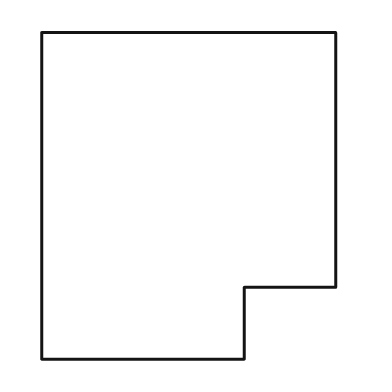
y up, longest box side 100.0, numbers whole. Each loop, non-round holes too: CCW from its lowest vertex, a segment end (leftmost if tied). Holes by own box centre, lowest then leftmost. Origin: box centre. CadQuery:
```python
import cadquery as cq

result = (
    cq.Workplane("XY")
    .moveTo(-45.0, -50.0)
    .lineTo(17.0, -50.0)
    .lineTo(17.0, -28.0)
    .lineTo(45.0, -28.0)
    .lineTo(45.0, 50.0)
    .lineTo(-45.0, 50.0)
    .close()
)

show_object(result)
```